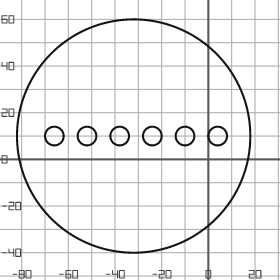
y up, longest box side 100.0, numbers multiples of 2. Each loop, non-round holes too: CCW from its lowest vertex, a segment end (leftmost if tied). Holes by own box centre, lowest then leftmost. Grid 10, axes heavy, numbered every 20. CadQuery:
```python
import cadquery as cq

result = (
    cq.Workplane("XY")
    .moveTo(-32.0, 10.0)
    .circle(50.0)
    .moveTo(-66.0, 10.0)
    .circle(4.0)
    .moveTo(-52.0, 10.0)
    .circle(4.0)
    .moveTo(-38.0, 10.0)
    .circle(4.0)
    .moveTo(-24.0, 10.0)
    .circle(4.0)
    .moveTo(-10.0, 10.0)
    .circle(4.0)
    .moveTo(4.0, 10.0)
    .circle(4.0)
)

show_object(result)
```